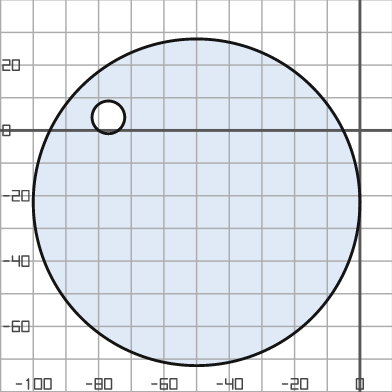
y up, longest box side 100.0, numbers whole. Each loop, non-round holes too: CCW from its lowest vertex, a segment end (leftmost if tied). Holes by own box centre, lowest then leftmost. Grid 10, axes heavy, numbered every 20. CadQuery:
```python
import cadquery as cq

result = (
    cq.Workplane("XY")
    .moveTo(-50.0, -22.0)
    .circle(50.0)
    .moveTo(-77.0, 4.0)
    .circle(5.0)
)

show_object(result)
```